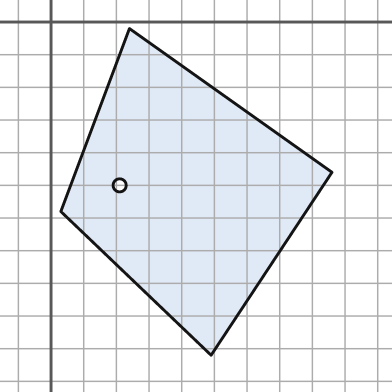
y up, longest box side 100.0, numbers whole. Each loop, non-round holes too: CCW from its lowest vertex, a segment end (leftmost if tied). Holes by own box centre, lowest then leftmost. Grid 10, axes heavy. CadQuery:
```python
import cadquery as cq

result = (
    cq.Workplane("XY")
    .moveTo(49.0, -102.0)
    .lineTo(86.0, -46.0)
    .lineTo(24.0, -2.0)
    .lineTo(3.0, -58.0)
    .close()
    .moveTo(21.0, -50.0)
    .circle(2.0)
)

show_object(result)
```